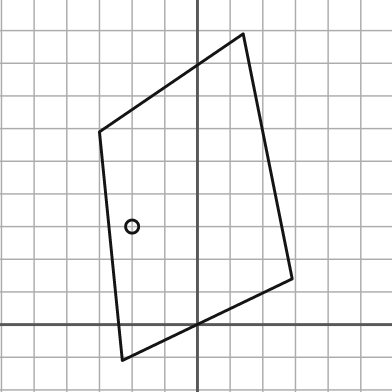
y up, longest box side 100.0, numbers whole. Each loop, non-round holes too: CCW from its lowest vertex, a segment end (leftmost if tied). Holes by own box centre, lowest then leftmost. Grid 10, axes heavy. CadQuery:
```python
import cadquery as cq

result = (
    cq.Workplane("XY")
    .moveTo(-23.0, -11.0)
    .lineTo(29.0, 14.0)
    .lineTo(14.0, 89.0)
    .lineTo(-30.0, 59.0)
    .close()
    .moveTo(-20.0, 30.0)
    .circle(2.0)
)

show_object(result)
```